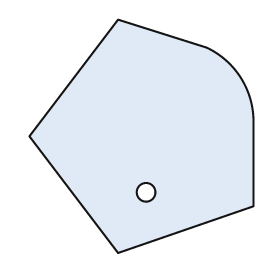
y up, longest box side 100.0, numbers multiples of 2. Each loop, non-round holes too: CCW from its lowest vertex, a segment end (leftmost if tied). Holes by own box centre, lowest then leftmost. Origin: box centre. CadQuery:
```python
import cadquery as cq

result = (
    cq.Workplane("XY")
    .moveTo(-10.0, -50.0)
    .lineTo(48.0, -30.0)
    .lineTo(48.0, 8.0)
    .threePointArc((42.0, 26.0), (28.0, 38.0))
    .lineTo(-10.0, 50.0)
    .lineTo(-48.0, 0.0)
    .close()
    .moveTo(2.0, -24.0)
    .circle(4.0)
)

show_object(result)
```